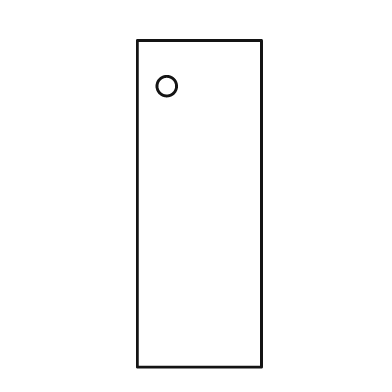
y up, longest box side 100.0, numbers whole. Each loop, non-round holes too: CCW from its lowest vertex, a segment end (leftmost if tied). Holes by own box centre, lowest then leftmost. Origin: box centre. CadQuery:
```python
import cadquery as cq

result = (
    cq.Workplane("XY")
    .moveTo(-19.0, -50.0)
    .lineTo(19.0, -50.0)
    .lineTo(19.0, 50.0)
    .lineTo(-19.0, 50.0)
    .close()
    .moveTo(-10.0, 36.0)
    .circle(3.0)
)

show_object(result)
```